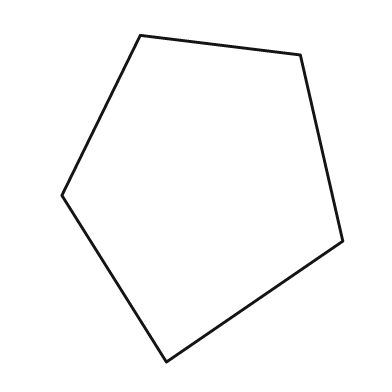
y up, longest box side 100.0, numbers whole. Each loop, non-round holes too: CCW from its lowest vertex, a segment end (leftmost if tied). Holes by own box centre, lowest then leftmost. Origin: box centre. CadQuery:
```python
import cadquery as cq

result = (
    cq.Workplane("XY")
    .moveTo(-11.0, -50.0)
    .lineTo(43.0, -13.0)
    .lineTo(30.0, 44.0)
    .lineTo(-19.0, 50.0)
    .lineTo(-43.0, 1.0)
    .close()
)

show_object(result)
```